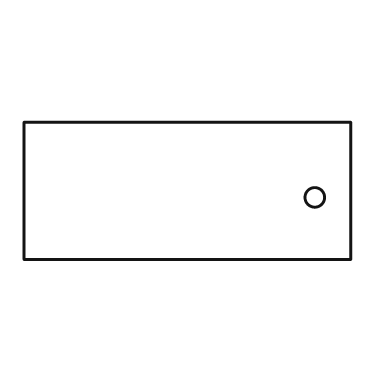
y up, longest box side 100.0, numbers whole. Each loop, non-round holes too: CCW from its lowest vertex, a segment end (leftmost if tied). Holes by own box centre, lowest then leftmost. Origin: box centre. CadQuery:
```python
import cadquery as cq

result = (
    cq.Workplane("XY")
    .moveTo(-50.0, -21.0)
    .lineTo(50.0, -21.0)
    .lineTo(50.0, 21.0)
    .lineTo(-50.0, 21.0)
    .close()
    .moveTo(39.0, -2.0)
    .circle(3.0)
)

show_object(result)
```